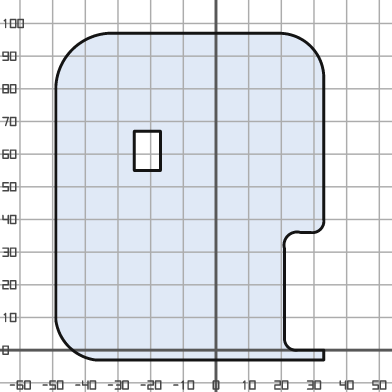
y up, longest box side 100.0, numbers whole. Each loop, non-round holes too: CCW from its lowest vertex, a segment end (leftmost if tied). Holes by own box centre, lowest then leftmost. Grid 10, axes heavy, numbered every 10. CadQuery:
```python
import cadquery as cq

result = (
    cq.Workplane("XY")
    .moveTo(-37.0, -3.0)
    .lineTo(33.0, -3.0)
    .lineTo(33.0, 0.0)
    .lineTo(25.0, 0.0)
    .threePointArc((22.0, 1.0), (21.0, 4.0))
    .lineTo(21.0, 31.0)
    .threePointArc((22.0, 35.0), (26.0, 36.0))
    .lineTo(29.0, 36.0)
    .threePointArc((32.0, 37.0), (33.0, 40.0))
    .lineTo(33.0, 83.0)
    .threePointArc((29.0, 93.0), (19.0, 97.0))
    .lineTo(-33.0, 97.0)
    .threePointArc((-44.0, 92.0), (-49.0, 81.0))
    .lineTo(-49.0, 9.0)
    .threePointArc((-45.0, 1.0), (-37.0, -3.0))
    .close()
    .moveTo(-25.0, 55.0)
    .lineTo(-17.0, 55.0)
    .lineTo(-17.0, 67.0)
    .lineTo(-25.0, 67.0)
    .close()
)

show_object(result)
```